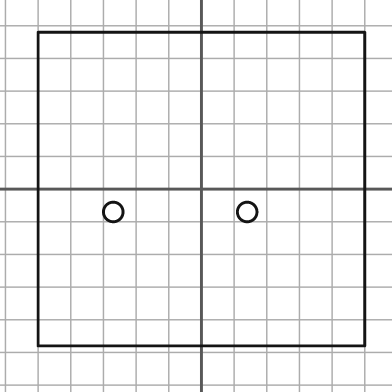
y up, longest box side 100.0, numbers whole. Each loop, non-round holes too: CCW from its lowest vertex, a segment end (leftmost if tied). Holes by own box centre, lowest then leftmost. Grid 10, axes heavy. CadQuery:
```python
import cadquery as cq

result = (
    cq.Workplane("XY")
    .moveTo(-50.0, -48.0)
    .lineTo(50.0, -48.0)
    .lineTo(50.0, 48.0)
    .lineTo(-50.0, 48.0)
    .close()
    .moveTo(-27.0, -7.0)
    .circle(3.0)
    .moveTo(14.0, -7.0)
    .circle(3.0)
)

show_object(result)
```